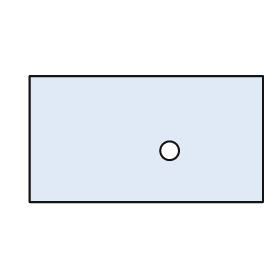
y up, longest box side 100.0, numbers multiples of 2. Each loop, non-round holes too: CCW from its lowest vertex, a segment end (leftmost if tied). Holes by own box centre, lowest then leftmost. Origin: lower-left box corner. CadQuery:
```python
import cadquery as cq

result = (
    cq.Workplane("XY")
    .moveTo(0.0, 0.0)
    .lineTo(100.0, 0.0)
    .lineTo(100.0, 54.0)
    .lineTo(0.0, 54.0)
    .close()
    .moveTo(60.0, 22.0)
    .circle(4.0)
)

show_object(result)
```